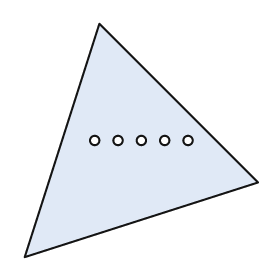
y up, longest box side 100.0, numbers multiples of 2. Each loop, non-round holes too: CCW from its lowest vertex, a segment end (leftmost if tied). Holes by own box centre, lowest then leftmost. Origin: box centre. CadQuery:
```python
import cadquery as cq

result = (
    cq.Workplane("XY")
    .moveTo(-50.0, -50.0)
    .lineTo(50.0, -18.0)
    .lineTo(-18.0, 50.0)
    .close()
    .moveTo(-20.0, 0.0)
    .circle(2.0)
    .moveTo(-10.0, 0.0)
    .circle(2.0)
    .moveTo(0.0, 0.0)
    .circle(2.0)
    .moveTo(10.0, 0.0)
    .circle(2.0)
    .moveTo(20.0, 0.0)
    .circle(2.0)
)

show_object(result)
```